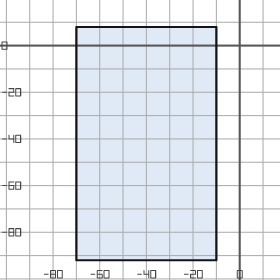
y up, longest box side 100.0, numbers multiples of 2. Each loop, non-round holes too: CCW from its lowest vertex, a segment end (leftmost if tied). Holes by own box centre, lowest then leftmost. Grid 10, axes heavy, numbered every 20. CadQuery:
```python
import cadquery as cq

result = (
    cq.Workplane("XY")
    .moveTo(-70.0, -92.0)
    .lineTo(-10.0, -92.0)
    .lineTo(-10.0, 8.0)
    .lineTo(-70.0, 8.0)
    .close()
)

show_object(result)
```